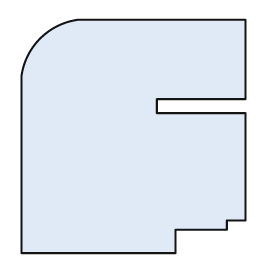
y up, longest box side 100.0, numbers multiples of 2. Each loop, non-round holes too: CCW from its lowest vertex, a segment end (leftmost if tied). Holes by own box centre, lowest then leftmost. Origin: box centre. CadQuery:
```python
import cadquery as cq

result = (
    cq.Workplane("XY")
    .moveTo(-48.0, -50.0)
    .lineTo(18.0, -50.0)
    .lineTo(18.0, -40.0)
    .lineTo(40.0, -40.0)
    .lineTo(40.0, -36.0)
    .lineTo(48.0, -36.0)
    .lineTo(48.0, 10.0)
    .lineTo(10.0, 10.0)
    .lineTo(10.0, 16.0)
    .lineTo(48.0, 16.0)
    .lineTo(48.0, 50.0)
    .lineTo(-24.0, 50.0)
    .threePointArc((-40.0, 42.0), (-48.0, 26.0))
    .close()
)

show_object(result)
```